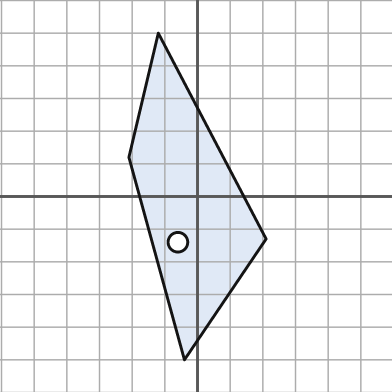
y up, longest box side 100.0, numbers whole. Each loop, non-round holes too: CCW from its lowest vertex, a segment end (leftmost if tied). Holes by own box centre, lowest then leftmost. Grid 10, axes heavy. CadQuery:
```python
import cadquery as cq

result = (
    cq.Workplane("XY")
    .moveTo(-4.0, -50.0)
    .lineTo(21.0, -13.0)
    .lineTo(-12.0, 50.0)
    .lineTo(-21.0, 12.0)
    .close()
    .moveTo(-6.0, -14.0)
    .circle(3.0)
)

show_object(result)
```